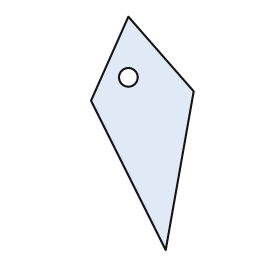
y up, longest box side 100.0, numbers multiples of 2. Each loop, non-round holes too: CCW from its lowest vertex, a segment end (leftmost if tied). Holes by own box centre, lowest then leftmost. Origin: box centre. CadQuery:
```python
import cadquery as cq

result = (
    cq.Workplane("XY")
    .moveTo(10.0, -50.0)
    .lineTo(22.0, 18.0)
    .lineTo(-6.0, 50.0)
    .lineTo(-22.0, 14.0)
    .close()
    .moveTo(-6.0, 24.0)
    .circle(4.0)
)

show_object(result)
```